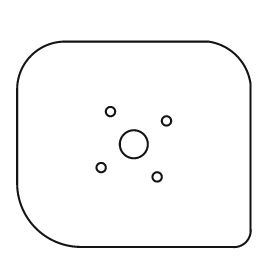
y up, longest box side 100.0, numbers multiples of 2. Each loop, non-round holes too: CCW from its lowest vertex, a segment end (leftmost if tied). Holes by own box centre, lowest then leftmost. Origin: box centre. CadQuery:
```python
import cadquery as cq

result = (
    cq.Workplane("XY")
    .moveTo(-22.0, -44.0)
    .lineTo(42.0, -44.0)
    .threePointArc((48.0, -42.0), (50.0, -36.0))
    .lineTo(50.0, 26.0)
    .threePointArc((44.0, 38.0), (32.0, 44.0))
    .lineTo(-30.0, 44.0)
    .threePointArc((-44.0, 38.0), (-50.0, 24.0))
    .lineTo(-50.0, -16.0)
    .threePointArc((-42.0, -36.0), (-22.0, -44.0))
    .close()
    .moveTo(10.0, -14.0)
    .circle(2.0)
    .moveTo(-14.0, -10.0)
    .circle(2.0)
    .moveTo(0.0, 0.0)
    .circle(6.0)
    .moveTo(14.0, 10.0)
    .circle(2.0)
    .moveTo(-10.0, 14.0)
    .circle(2.0)
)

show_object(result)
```